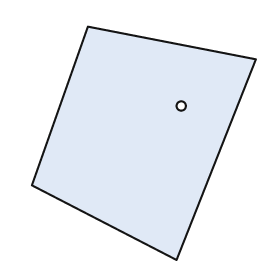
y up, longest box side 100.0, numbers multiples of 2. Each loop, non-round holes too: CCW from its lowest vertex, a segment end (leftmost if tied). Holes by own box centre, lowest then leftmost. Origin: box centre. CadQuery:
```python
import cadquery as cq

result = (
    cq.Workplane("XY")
    .moveTo(14.0, -50.0)
    .lineTo(48.0, 36.0)
    .lineTo(-24.0, 50.0)
    .lineTo(-48.0, -18.0)
    .close()
    .moveTo(16.0, 16.0)
    .circle(2.0)
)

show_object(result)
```